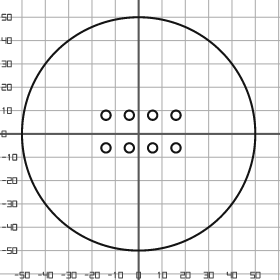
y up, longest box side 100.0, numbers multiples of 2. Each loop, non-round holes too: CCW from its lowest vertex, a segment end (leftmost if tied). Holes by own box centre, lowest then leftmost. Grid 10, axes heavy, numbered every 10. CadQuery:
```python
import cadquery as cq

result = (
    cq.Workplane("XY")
    .moveTo(0.0, 0.0)
    .circle(50.0)
    .moveTo(-14.0, -6.0)
    .circle(2.0)
    .moveTo(-4.0, -6.0)
    .circle(2.0)
    .moveTo(6.0, -6.0)
    .circle(2.0)
    .moveTo(16.0, -6.0)
    .circle(2.0)
    .moveTo(-14.0, 8.0)
    .circle(2.0)
    .moveTo(-4.0, 8.0)
    .circle(2.0)
    .moveTo(6.0, 8.0)
    .circle(2.0)
    .moveTo(16.0, 8.0)
    .circle(2.0)
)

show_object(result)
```